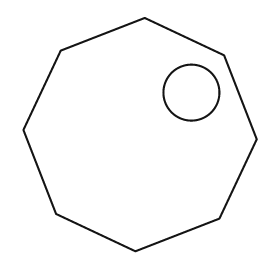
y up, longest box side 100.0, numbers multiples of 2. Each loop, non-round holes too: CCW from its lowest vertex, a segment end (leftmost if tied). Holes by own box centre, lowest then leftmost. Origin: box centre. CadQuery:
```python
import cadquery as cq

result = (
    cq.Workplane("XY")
    .moveTo(-2.0, -50.0)
    .lineTo(34.0, -36.0)
    .lineTo(50.0, -2.0)
    .lineTo(36.0, 34.0)
    .lineTo(2.0, 50.0)
    .lineTo(-34.0, 36.0)
    .lineTo(-50.0, 2.0)
    .lineTo(-36.0, -34.0)
    .close()
    .moveTo(22.0, 18.0)
    .circle(12.0)
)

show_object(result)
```